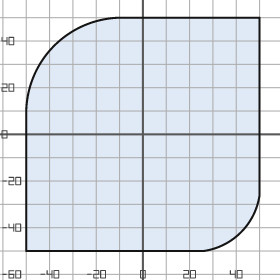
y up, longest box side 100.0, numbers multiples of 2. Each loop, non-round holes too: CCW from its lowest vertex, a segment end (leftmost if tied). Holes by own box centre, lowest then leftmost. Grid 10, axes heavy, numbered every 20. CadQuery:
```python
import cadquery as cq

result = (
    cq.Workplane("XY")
    .moveTo(-50.0, -50.0)
    .lineTo(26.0, -50.0)
    .threePointArc((42.0, -42.0), (50.0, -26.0))
    .lineTo(50.0, 50.0)
    .lineTo(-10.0, 50.0)
    .threePointArc((-38.0, 38.0), (-50.0, 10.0))
    .close()
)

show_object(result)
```